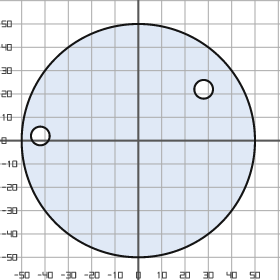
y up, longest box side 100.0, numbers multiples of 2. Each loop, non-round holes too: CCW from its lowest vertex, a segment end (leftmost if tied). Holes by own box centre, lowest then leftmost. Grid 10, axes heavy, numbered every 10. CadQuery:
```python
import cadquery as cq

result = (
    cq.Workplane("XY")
    .moveTo(0.0, 0.0)
    .circle(50.0)
    .moveTo(-42.0, 2.0)
    .circle(4.0)
    .moveTo(28.0, 22.0)
    .circle(4.0)
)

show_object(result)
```